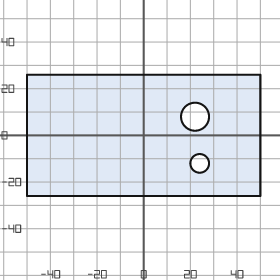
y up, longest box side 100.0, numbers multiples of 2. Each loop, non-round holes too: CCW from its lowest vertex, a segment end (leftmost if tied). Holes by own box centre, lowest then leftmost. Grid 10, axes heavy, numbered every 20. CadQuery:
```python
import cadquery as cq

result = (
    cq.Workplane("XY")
    .moveTo(-50.0, -26.0)
    .lineTo(50.0, -26.0)
    .lineTo(50.0, 26.0)
    .lineTo(-50.0, 26.0)
    .close()
    .moveTo(24.0, -12.0)
    .circle(4.0)
    .moveTo(22.0, 8.0)
    .circle(6.0)
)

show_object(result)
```